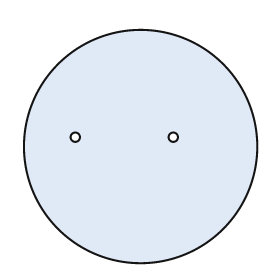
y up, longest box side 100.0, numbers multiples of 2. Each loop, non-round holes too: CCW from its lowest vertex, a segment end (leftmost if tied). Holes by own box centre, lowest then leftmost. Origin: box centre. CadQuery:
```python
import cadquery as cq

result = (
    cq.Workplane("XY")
    .moveTo(0.0, 0.0)
    .circle(50.0)
    .moveTo(-28.0, 4.0)
    .circle(2.0)
    .moveTo(14.0, 4.0)
    .circle(2.0)
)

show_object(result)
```